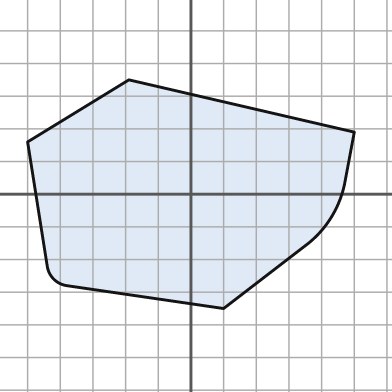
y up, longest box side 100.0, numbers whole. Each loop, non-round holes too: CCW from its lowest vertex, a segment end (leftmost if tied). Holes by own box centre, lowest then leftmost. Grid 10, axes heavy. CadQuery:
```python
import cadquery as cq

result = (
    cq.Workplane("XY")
    .moveTo(10.0, -35.0)
    .lineTo(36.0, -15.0)
    .threePointArc((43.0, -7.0), (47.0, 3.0))
    .lineTo(50.0, 19.0)
    .lineTo(-19.0, 35.0)
    .lineTo(-50.0, 16.0)
    .lineTo(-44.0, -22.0)
    .threePointArc((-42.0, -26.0), (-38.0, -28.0))
    .close()
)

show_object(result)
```